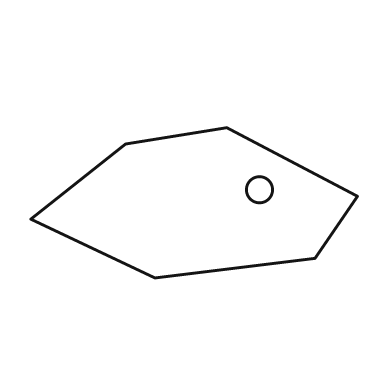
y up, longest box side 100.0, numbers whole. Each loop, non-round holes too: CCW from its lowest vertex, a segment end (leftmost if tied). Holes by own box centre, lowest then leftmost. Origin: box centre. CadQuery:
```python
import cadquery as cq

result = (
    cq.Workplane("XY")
    .moveTo(-12.0, -23.0)
    .lineTo(37.0, -17.0)
    .lineTo(50.0, 2.0)
    .lineTo(10.0, 23.0)
    .lineTo(-21.0, 18.0)
    .lineTo(-50.0, -5.0)
    .close()
    .moveTo(20.0, 4.0)
    .circle(4.0)
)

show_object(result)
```